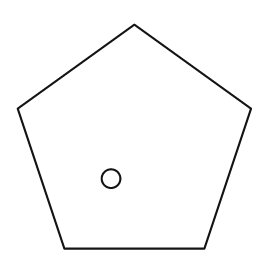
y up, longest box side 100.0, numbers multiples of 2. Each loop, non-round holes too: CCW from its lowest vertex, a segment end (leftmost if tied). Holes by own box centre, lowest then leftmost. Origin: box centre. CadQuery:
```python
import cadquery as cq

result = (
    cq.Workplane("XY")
    .moveTo(-30.0, -48.0)
    .lineTo(30.0, -48.0)
    .lineTo(50.0, 12.0)
    .lineTo(0.0, 48.0)
    .lineTo(-50.0, 12.0)
    .close()
    .moveTo(-10.0, -18.0)
    .circle(4.0)
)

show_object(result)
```